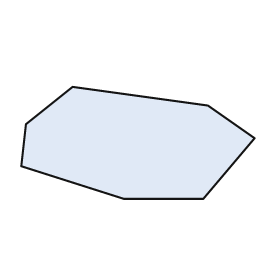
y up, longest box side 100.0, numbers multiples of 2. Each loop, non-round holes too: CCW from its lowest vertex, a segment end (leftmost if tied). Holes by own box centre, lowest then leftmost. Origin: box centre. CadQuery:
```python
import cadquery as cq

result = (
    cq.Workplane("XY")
    .moveTo(-6.0, -24.0)
    .lineTo(28.0, -24.0)
    .lineTo(50.0, 2.0)
    .lineTo(30.0, 16.0)
    .lineTo(-28.0, 24.0)
    .lineTo(-48.0, 8.0)
    .lineTo(-50.0, -10.0)
    .close()
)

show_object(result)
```